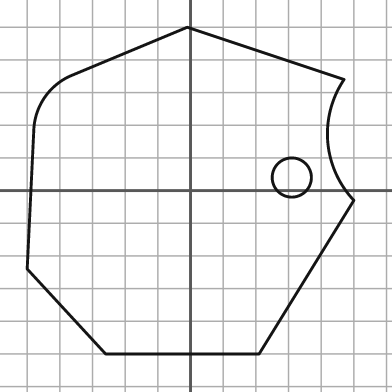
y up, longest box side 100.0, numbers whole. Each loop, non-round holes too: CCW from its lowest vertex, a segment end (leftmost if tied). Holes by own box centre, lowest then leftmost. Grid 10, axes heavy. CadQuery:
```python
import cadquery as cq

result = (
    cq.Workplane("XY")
    .moveTo(-26.0, -50.0)
    .lineTo(21.0, -50.0)
    .lineTo(50.0, -3.0)
    .threePointArc((42.0, 15.0), (47.0, 34.0))
    .lineTo(-1.0, 50.0)
    .lineTo(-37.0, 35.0)
    .threePointArc((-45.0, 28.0), (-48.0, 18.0))
    .lineTo(-50.0, -24.0)
    .close()
    .moveTo(31.0, 4.0)
    .circle(6.0)
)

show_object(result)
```